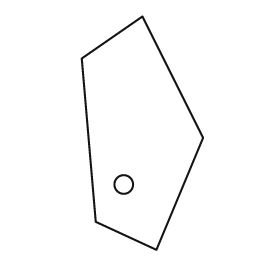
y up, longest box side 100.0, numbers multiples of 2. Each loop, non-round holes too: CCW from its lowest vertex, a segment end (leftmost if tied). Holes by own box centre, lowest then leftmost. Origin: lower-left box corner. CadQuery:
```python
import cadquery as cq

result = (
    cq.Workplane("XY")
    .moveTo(32.0, 0.0)
    .lineTo(52.0, 48.0)
    .lineTo(26.0, 100.0)
    .lineTo(0.0, 82.0)
    .lineTo(6.0, 12.0)
    .close()
    .moveTo(18.0, 28.0)
    .circle(4.0)
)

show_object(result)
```